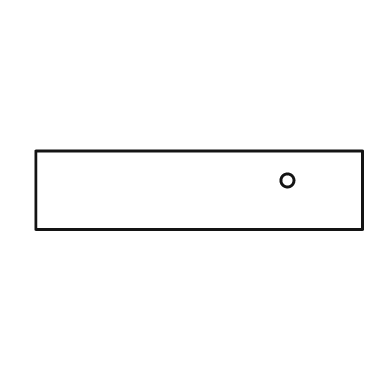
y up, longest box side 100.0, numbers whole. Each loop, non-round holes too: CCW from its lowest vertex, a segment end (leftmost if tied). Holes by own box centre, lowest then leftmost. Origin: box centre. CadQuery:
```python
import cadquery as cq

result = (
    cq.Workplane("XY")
    .moveTo(-50.0, -12.0)
    .lineTo(50.0, -12.0)
    .lineTo(50.0, 12.0)
    .lineTo(-50.0, 12.0)
    .close()
    .moveTo(27.0, 3.0)
    .circle(2.0)
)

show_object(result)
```